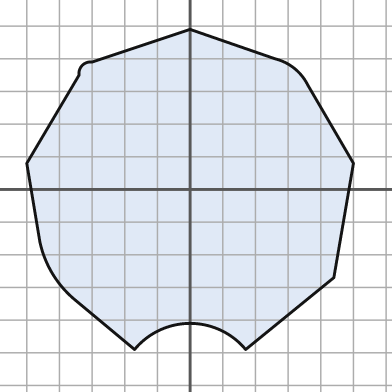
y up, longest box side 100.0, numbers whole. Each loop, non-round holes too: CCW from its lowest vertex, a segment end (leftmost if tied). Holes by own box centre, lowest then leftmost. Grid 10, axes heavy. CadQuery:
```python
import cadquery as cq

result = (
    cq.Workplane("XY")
    .moveTo(-17.0, -49.0)
    .threePointArc((0.0, -41.0), (17.0, -49.0))
    .lineTo(44.0, -27.0)
    .lineTo(50.0, 8.0)
    .lineTo(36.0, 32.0)
    .threePointArc((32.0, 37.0), (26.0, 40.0))
    .lineTo(0.0, 49.0)
    .lineTo(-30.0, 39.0)
    .threePointArc((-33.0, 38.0), (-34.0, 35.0))
    .lineTo(-50.0, 8.0)
    .lineTo(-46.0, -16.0)
    .threePointArc((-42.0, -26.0), (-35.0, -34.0))
    .close()
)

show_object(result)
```